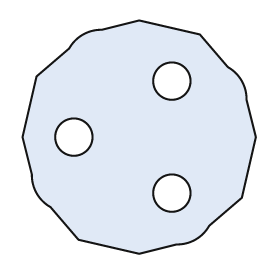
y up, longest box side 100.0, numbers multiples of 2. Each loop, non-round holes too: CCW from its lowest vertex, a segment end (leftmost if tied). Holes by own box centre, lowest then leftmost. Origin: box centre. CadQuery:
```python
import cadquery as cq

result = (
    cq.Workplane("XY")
    .moveTo(0.0, -50.0)
    .lineTo(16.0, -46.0)
    .threePointArc((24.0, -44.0), (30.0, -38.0))
    .lineTo(44.0, -26.0)
    .lineTo(50.0, 0.0)
    .lineTo(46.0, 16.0)
    .threePointArc((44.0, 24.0), (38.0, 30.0))
    .lineTo(26.0, 44.0)
    .lineTo(0.0, 50.0)
    .lineTo(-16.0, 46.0)
    .threePointArc((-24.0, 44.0), (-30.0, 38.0))
    .lineTo(-44.0, 26.0)
    .lineTo(-50.0, 0.0)
    .lineTo(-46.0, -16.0)
    .threePointArc((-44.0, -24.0), (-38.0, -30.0))
    .lineTo(-26.0, -44.0)
    .close()
    .moveTo(14.0, -24.0)
    .circle(8.0)
    .moveTo(-28.0, 0.0)
    .circle(8.0)
    .moveTo(14.0, 24.0)
    .circle(8.0)
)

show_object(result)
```